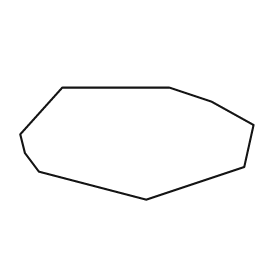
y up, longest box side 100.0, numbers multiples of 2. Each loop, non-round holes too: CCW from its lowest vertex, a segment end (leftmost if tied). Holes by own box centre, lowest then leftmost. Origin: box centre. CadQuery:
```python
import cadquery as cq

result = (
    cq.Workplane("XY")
    .moveTo(4.0, -24.0)
    .lineTo(46.0, -10.0)
    .lineTo(50.0, 8.0)
    .lineTo(32.0, 18.0)
    .lineTo(14.0, 24.0)
    .lineTo(-32.0, 24.0)
    .lineTo(-50.0, 4.0)
    .lineTo(-48.0, -4.0)
    .lineTo(-42.0, -12.0)
    .close()
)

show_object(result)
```